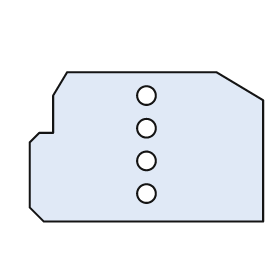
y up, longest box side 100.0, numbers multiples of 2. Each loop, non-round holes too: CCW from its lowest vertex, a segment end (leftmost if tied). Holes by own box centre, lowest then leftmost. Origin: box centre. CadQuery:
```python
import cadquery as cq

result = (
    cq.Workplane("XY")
    .moveTo(-44.0, -32.0)
    .lineTo(50.0, -32.0)
    .lineTo(50.0, 20.0)
    .lineTo(30.0, 32.0)
    .lineTo(-34.0, 32.0)
    .lineTo(-40.0, 22.0)
    .lineTo(-40.0, 6.0)
    .lineTo(-46.0, 6.0)
    .lineTo(-50.0, 2.0)
    .lineTo(-50.0, -26.0)
    .close()
    .moveTo(0.0, -20.0)
    .circle(4.0)
    .moveTo(0.0, -6.0)
    .circle(4.0)
    .moveTo(0.0, 8.0)
    .circle(4.0)
    .moveTo(0.0, 22.0)
    .circle(4.0)
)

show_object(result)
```